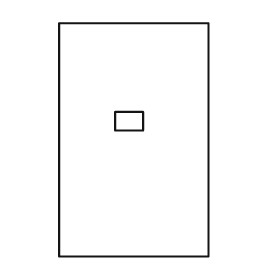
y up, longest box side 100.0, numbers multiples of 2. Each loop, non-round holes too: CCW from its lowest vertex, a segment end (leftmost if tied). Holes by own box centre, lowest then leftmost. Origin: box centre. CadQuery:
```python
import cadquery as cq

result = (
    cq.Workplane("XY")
    .moveTo(-32.0, -50.0)
    .lineTo(32.0, -50.0)
    .lineTo(32.0, 50.0)
    .lineTo(-32.0, 50.0)
    .close()
    .moveTo(-8.0, 4.0)
    .lineTo(4.0, 4.0)
    .lineTo(4.0, 12.0)
    .lineTo(-8.0, 12.0)
    .close()
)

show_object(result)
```